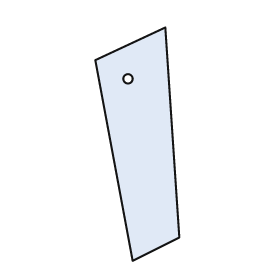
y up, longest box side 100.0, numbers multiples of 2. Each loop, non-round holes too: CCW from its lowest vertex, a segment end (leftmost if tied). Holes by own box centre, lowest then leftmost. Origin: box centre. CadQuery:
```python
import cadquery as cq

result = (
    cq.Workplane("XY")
    .moveTo(-2.0, -50.0)
    .lineTo(18.0, -40.0)
    .lineTo(12.0, 50.0)
    .lineTo(-18.0, 36.0)
    .close()
    .moveTo(-4.0, 28.0)
    .circle(2.0)
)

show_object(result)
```